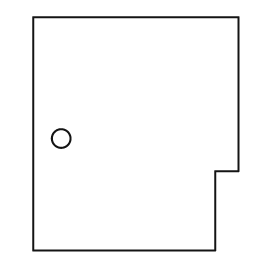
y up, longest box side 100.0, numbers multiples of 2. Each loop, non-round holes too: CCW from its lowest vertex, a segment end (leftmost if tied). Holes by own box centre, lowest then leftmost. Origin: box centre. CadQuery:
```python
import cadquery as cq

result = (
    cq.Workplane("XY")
    .moveTo(-44.0, -50.0)
    .lineTo(34.0, -50.0)
    .lineTo(34.0, -16.0)
    .lineTo(44.0, -16.0)
    .lineTo(44.0, 50.0)
    .lineTo(-44.0, 50.0)
    .close()
    .moveTo(-32.0, -2.0)
    .circle(4.0)
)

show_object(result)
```